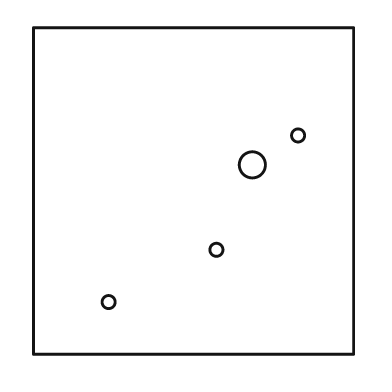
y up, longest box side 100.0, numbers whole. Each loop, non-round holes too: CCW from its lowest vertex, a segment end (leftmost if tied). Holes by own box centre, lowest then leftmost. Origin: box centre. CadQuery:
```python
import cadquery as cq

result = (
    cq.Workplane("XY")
    .moveTo(-49.0, -50.0)
    .lineTo(49.0, -50.0)
    .lineTo(49.0, 50.0)
    .lineTo(-49.0, 50.0)
    .close()
    .moveTo(-26.0, -34.0)
    .circle(2.0)
    .moveTo(7.0, -18.0)
    .circle(2.0)
    .moveTo(18.0, 8.0)
    .circle(4.0)
    .moveTo(32.0, 17.0)
    .circle(2.0)
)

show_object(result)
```